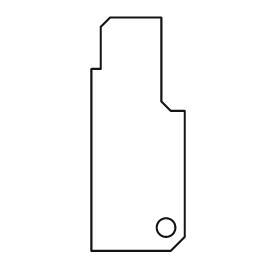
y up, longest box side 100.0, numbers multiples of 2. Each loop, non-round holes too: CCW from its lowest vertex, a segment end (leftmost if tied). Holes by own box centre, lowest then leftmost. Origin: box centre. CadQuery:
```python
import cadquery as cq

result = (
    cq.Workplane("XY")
    .moveTo(-20.0, -50.0)
    .lineTo(14.0, -50.0)
    .lineTo(20.0, -44.0)
    .lineTo(20.0, 10.0)
    .lineTo(14.0, 10.0)
    .lineTo(10.0, 14.0)
    .lineTo(10.0, 50.0)
    .lineTo(-12.0, 50.0)
    .lineTo(-16.0, 46.0)
    .lineTo(-16.0, 28.0)
    .lineTo(-20.0, 28.0)
    .close()
    .moveTo(12.0, -40.0)
    .circle(4.0)
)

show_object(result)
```